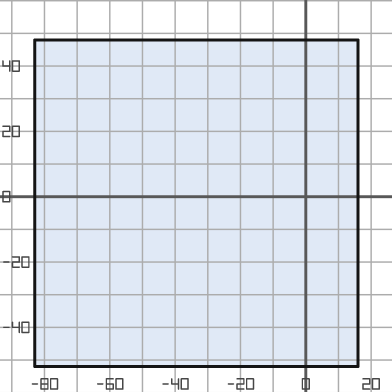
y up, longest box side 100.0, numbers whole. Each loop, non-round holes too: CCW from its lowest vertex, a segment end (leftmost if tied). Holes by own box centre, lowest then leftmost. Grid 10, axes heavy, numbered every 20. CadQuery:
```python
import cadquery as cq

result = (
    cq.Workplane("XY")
    .moveTo(-83.0, -52.0)
    .lineTo(16.0, -52.0)
    .lineTo(16.0, 48.0)
    .lineTo(-83.0, 48.0)
    .close()
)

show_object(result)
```